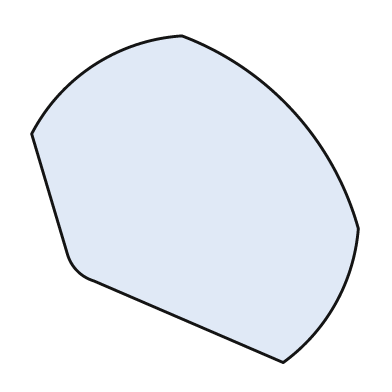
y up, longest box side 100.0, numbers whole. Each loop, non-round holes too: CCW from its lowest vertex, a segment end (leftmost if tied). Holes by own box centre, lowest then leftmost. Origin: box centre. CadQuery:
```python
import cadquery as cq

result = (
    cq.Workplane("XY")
    .moveTo(27.0, -50.0)
    .threePointArc((43.0, -32.0), (50.0, -9.0))
    .threePointArc((30.0, 27.0), (-4.0, 50.0))
    .threePointArc((-31.0, 41.0), (-50.0, 20.0))
    .lineTo(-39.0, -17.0)
    .threePointArc((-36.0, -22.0), (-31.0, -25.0))
    .close()
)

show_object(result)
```